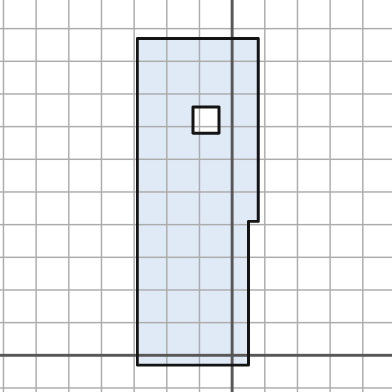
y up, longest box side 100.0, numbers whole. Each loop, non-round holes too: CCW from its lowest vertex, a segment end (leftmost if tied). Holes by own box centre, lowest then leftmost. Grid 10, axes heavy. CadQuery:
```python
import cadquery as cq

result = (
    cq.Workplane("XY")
    .moveTo(-29.0, -3.0)
    .lineTo(5.0, -3.0)
    .lineTo(5.0, 41.0)
    .lineTo(8.0, 41.0)
    .lineTo(8.0, 97.0)
    .lineTo(-29.0, 97.0)
    .close()
    .moveTo(-12.0, 68.0)
    .lineTo(-4.0, 68.0)
    .lineTo(-4.0, 76.0)
    .lineTo(-12.0, 76.0)
    .close()
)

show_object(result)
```